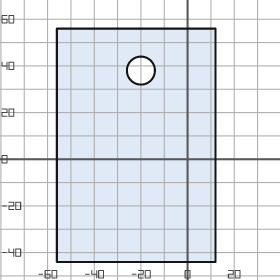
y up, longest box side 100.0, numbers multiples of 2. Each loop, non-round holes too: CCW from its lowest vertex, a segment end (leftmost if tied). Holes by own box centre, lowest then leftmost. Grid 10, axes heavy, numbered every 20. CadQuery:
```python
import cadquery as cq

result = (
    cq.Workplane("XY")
    .moveTo(-56.0, -44.0)
    .lineTo(12.0, -44.0)
    .lineTo(12.0, 56.0)
    .lineTo(-56.0, 56.0)
    .close()
    .moveTo(-20.0, 38.0)
    .circle(6.0)
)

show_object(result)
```